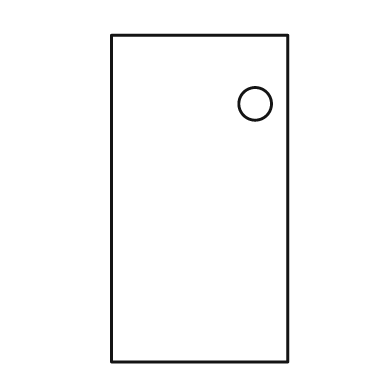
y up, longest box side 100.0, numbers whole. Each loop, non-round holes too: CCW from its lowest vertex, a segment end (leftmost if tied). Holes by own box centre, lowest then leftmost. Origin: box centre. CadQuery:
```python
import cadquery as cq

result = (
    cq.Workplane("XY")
    .moveTo(-27.0, -50.0)
    .lineTo(27.0, -50.0)
    .lineTo(27.0, 50.0)
    .lineTo(-27.0, 50.0)
    .close()
    .moveTo(17.0, 29.0)
    .circle(5.0)
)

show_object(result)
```